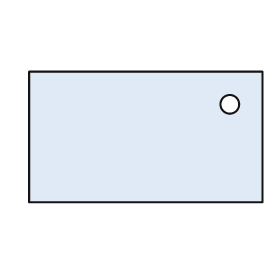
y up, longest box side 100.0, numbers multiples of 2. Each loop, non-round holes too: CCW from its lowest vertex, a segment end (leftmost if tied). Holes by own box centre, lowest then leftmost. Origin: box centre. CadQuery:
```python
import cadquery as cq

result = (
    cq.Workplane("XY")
    .moveTo(-50.0, -28.0)
    .lineTo(50.0, -28.0)
    .lineTo(50.0, 28.0)
    .lineTo(-50.0, 28.0)
    .close()
    .moveTo(36.0, 14.0)
    .circle(4.0)
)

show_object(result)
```